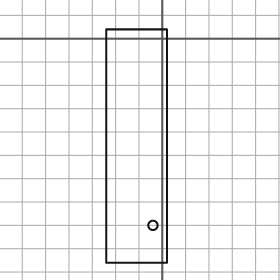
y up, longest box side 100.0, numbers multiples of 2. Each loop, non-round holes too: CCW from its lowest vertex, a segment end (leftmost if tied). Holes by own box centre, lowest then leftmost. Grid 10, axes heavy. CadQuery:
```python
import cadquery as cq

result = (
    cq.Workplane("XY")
    .moveTo(-24.0, -96.0)
    .lineTo(2.0, -96.0)
    .lineTo(2.0, 4.0)
    .lineTo(-24.0, 4.0)
    .close()
    .moveTo(-4.0, -80.0)
    .circle(2.0)
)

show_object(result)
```